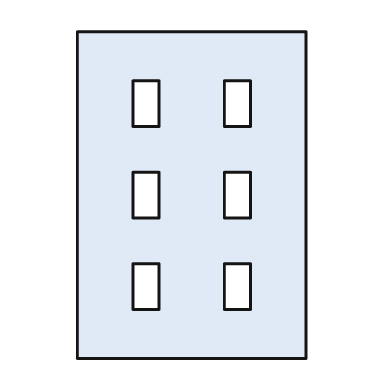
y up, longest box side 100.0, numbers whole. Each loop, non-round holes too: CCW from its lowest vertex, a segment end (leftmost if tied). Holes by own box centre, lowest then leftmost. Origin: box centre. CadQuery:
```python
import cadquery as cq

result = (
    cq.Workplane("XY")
    .moveTo(-35.0, -50.0)
    .lineTo(35.0, -50.0)
    .lineTo(35.0, 50.0)
    .lineTo(-35.0, 50.0)
    .close()
    .moveTo(-18.0, -35.0)
    .lineTo(-10.0, -35.0)
    .lineTo(-10.0, -21.0)
    .lineTo(-18.0, -21.0)
    .close()
    .moveTo(10.0, -35.0)
    .lineTo(18.0, -35.0)
    .lineTo(18.0, -21.0)
    .lineTo(10.0, -21.0)
    .close()
    .moveTo(-18.0, -7.0)
    .lineTo(-10.0, -7.0)
    .lineTo(-10.0, 7.0)
    .lineTo(-18.0, 7.0)
    .close()
    .moveTo(10.0, -7.0)
    .lineTo(18.0, -7.0)
    .lineTo(18.0, 7.0)
    .lineTo(10.0, 7.0)
    .close()
    .moveTo(-18.0, 21.0)
    .lineTo(-10.0, 21.0)
    .lineTo(-10.0, 35.0)
    .lineTo(-18.0, 35.0)
    .close()
    .moveTo(10.0, 21.0)
    .lineTo(18.0, 21.0)
    .lineTo(18.0, 35.0)
    .lineTo(10.0, 35.0)
    .close()
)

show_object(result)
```